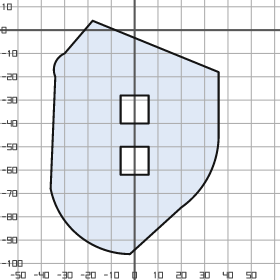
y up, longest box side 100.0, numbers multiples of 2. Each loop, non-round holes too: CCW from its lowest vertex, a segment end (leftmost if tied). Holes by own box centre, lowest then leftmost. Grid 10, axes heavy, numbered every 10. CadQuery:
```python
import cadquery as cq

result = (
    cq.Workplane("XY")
    .moveTo(-2.0, -96.0)
    .lineTo(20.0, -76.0)
    .threePointArc((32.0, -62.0), (36.0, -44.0))
    .lineTo(36.0, -18.0)
    .lineTo(-18.0, 4.0)
    .lineTo(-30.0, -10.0)
    .threePointArc((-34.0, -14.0), (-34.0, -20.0))
    .lineTo(-36.0, -68.0)
    .threePointArc((-24.0, -88.0), (-2.0, -96.0))
    .close()
    .moveTo(-6.0, -62.0)
    .lineTo(6.0, -62.0)
    .lineTo(6.0, -50.0)
    .lineTo(-6.0, -50.0)
    .close()
    .moveTo(-6.0, -40.0)
    .lineTo(6.0, -40.0)
    .lineTo(6.0, -28.0)
    .lineTo(-6.0, -28.0)
    .close()
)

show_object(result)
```